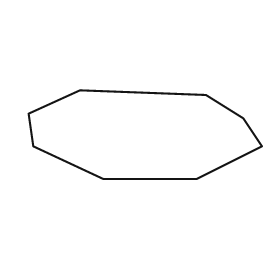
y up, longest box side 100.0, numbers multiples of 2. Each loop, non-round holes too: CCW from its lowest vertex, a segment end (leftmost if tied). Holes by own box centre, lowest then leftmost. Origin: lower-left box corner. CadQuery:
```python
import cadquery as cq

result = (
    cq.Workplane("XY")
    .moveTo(32.0, 0.0)
    .lineTo(72.0, 0.0)
    .lineTo(100.0, 14.0)
    .lineTo(92.0, 26.0)
    .lineTo(76.0, 36.0)
    .lineTo(22.0, 38.0)
    .lineTo(0.0, 28.0)
    .lineTo(2.0, 14.0)
    .close()
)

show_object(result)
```